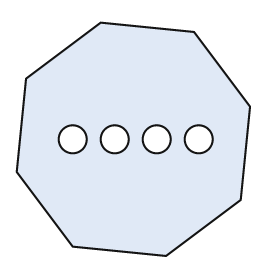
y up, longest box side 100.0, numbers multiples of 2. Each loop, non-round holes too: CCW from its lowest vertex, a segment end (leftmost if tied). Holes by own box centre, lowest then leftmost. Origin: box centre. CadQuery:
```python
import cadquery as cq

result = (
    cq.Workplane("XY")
    .moveTo(14.0, -50.0)
    .lineTo(46.0, -26.0)
    .lineTo(50.0, 14.0)
    .lineTo(26.0, 46.0)
    .lineTo(-14.0, 50.0)
    .lineTo(-46.0, 26.0)
    .lineTo(-50.0, -14.0)
    .lineTo(-26.0, -46.0)
    .close()
    .moveTo(-26.0, 0.0)
    .circle(6.0)
    .moveTo(-8.0, 0.0)
    .circle(6.0)
    .moveTo(10.0, 0.0)
    .circle(6.0)
    .moveTo(28.0, 0.0)
    .circle(6.0)
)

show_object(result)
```